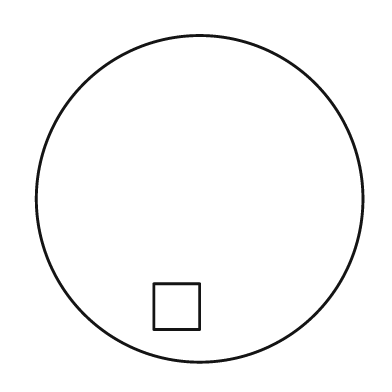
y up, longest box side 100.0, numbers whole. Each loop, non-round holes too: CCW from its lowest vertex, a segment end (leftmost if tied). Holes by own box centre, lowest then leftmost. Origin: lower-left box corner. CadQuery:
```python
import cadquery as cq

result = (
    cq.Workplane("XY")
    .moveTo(50.0, 50.0)
    .circle(50.0)
    .moveTo(36.0, 10.0)
    .lineTo(50.0, 10.0)
    .lineTo(50.0, 24.0)
    .lineTo(36.0, 24.0)
    .close()
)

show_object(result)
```